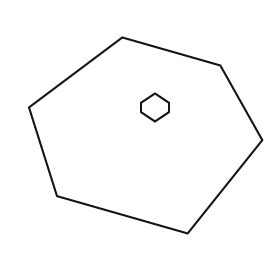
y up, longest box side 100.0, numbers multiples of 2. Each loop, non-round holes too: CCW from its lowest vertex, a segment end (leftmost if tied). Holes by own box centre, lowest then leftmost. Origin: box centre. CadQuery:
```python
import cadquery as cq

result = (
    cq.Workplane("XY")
    .moveTo(18.0, -42.0)
    .lineTo(50.0, -2.0)
    .lineTo(32.0, 30.0)
    .lineTo(-10.0, 42.0)
    .lineTo(-50.0, 12.0)
    .lineTo(-38.0, -26.0)
    .close()
    .moveTo(4.0, 6.0)
    .lineTo(10.0, 10.0)
    .lineTo(10.0, 14.0)
    .lineTo(4.0, 18.0)
    .lineTo(-2.0, 14.0)
    .lineTo(-2.0, 10.0)
    .close()
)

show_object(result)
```